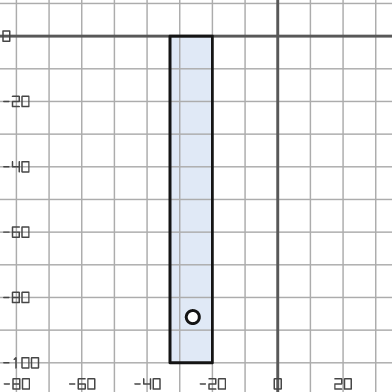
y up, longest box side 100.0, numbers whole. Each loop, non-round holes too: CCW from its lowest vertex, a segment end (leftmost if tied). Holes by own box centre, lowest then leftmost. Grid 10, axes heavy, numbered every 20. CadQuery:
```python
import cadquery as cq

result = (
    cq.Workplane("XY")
    .moveTo(-33.0, -100.0)
    .lineTo(-20.0, -100.0)
    .lineTo(-20.0, 0.0)
    .lineTo(-33.0, 0.0)
    .close()
    .moveTo(-26.0, -86.0)
    .circle(2.0)
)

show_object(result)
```